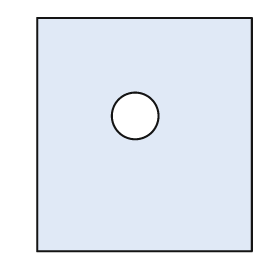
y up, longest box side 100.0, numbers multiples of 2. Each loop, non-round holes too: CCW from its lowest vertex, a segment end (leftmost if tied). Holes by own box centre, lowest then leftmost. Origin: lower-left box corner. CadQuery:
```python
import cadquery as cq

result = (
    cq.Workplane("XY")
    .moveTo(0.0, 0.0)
    .lineTo(92.0, 0.0)
    .lineTo(92.0, 100.0)
    .lineTo(0.0, 100.0)
    .close()
    .moveTo(42.0, 58.0)
    .circle(10.0)
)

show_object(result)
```